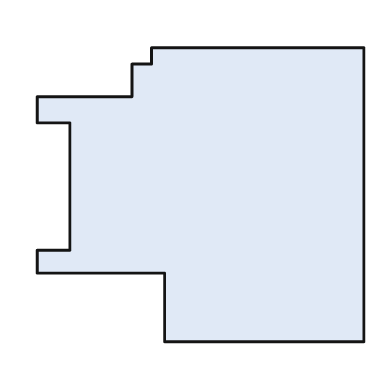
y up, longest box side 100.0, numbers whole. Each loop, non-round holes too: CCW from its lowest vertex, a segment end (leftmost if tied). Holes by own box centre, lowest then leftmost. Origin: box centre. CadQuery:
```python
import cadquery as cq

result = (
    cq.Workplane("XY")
    .moveTo(-11.0, -45.0)
    .lineTo(50.0, -45.0)
    .lineTo(50.0, 45.0)
    .lineTo(-15.0, 45.0)
    .lineTo(-15.0, 40.0)
    .lineTo(-21.0, 40.0)
    .lineTo(-21.0, 30.0)
    .lineTo(-50.0, 30.0)
    .lineTo(-50.0, 22.0)
    .lineTo(-40.0, 22.0)
    .lineTo(-40.0, -17.0)
    .lineTo(-50.0, -17.0)
    .lineTo(-50.0, -24.0)
    .lineTo(-11.0, -24.0)
    .close()
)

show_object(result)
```